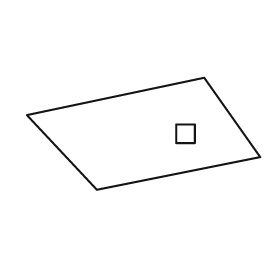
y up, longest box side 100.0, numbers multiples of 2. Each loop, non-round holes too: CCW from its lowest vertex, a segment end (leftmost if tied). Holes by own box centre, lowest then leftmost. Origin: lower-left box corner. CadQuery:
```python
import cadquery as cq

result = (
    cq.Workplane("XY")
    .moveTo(30.0, 0.0)
    .lineTo(100.0, 14.0)
    .lineTo(76.0, 48.0)
    .lineTo(0.0, 32.0)
    .close()
    .moveTo(64.0, 20.0)
    .lineTo(72.0, 20.0)
    .lineTo(72.0, 28.0)
    .lineTo(64.0, 28.0)
    .close()
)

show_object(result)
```